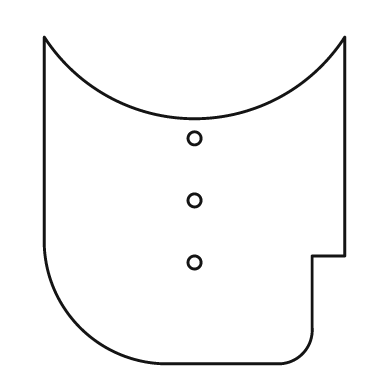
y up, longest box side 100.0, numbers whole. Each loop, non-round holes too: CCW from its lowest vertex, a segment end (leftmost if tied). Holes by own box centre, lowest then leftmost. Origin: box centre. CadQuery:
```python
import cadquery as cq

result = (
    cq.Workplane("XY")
    .moveTo(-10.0, -50.0)
    .lineTo(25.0, -50.0)
    .threePointArc((33.0, -47.0), (36.0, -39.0))
    .lineTo(36.0, -17.0)
    .lineTo(46.0, -17.0)
    .lineTo(46.0, 50.0)
    .threePointArc((0.0, 25.0), (-46.0, 50.0))
    .lineTo(-46.0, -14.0)
    .threePointArc((-35.0, -39.0), (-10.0, -50.0))
    .close()
    .moveTo(0.0, -19.0)
    .circle(2.0)
    .moveTo(0.0, 0.0)
    .circle(2.0)
    .moveTo(0.0, 19.0)
    .circle(2.0)
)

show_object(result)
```